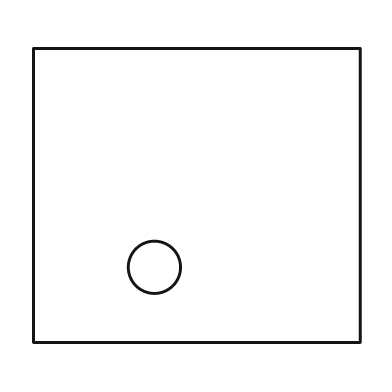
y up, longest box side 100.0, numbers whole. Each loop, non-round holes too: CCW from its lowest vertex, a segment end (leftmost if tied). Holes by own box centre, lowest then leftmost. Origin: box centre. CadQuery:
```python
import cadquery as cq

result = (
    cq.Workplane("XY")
    .moveTo(-50.0, -45.0)
    .lineTo(50.0, -45.0)
    .lineTo(50.0, 45.0)
    .lineTo(-50.0, 45.0)
    .close()
    .moveTo(-13.0, -22.0)
    .circle(8.0)
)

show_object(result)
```